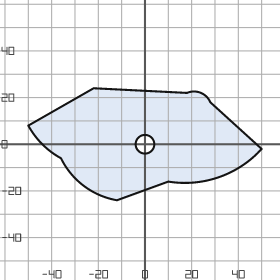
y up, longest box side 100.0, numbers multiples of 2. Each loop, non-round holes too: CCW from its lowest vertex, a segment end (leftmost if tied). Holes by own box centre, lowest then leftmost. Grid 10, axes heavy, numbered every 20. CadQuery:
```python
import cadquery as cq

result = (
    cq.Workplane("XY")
    .moveTo(-12.0, -24.0)
    .lineTo(10.0, -16.0)
    .threePointArc((32.0, -14.0), (50.0, -2.0))
    .lineTo(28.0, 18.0)
    .threePointArc((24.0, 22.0), (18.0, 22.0))
    .lineTo(-22.0, 24.0)
    .lineTo(-50.0, 8.0)
    .threePointArc((-44.0, 0.0), (-36.0, -6.0))
    .threePointArc((-26.0, -18.0), (-12.0, -24.0))
    .close()
    .moveTo(0.0, 0.0)
    .circle(4.0)
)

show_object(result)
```